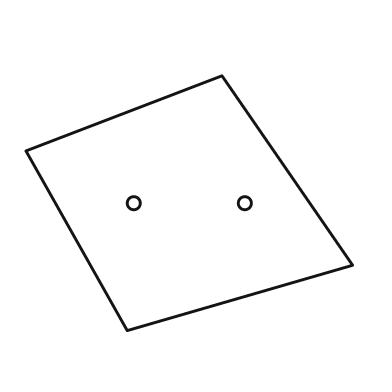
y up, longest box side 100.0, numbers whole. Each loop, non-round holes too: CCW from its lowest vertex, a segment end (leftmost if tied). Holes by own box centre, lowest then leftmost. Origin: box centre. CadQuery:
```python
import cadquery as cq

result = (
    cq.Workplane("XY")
    .moveTo(-19.0, -39.0)
    .lineTo(50.0, -19.0)
    .lineTo(10.0, 39.0)
    .lineTo(-50.0, 16.0)
    .close()
    .moveTo(-17.0, 0.0)
    .circle(2.0)
    .moveTo(17.0, 0.0)
    .circle(2.0)
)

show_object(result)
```